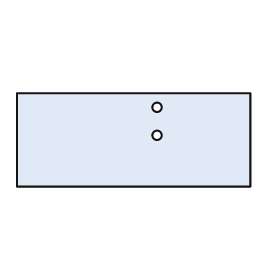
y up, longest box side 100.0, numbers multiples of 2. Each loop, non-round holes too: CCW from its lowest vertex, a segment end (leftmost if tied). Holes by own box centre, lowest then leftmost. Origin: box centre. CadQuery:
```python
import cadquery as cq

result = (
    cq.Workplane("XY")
    .moveTo(-50.0, -20.0)
    .lineTo(50.0, -20.0)
    .lineTo(50.0, 20.0)
    .lineTo(-50.0, 20.0)
    .close()
    .moveTo(10.0, 2.0)
    .circle(2.0)
    .moveTo(10.0, 14.0)
    .circle(2.0)
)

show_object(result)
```